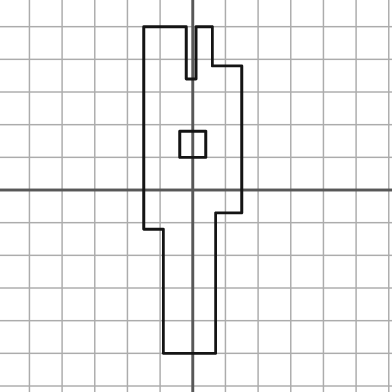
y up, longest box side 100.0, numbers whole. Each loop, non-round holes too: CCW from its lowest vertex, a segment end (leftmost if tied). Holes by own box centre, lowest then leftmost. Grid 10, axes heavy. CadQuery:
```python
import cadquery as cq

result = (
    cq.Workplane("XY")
    .moveTo(-9.0, -50.0)
    .lineTo(7.0, -50.0)
    .lineTo(7.0, -7.0)
    .lineTo(15.0, -7.0)
    .lineTo(15.0, 38.0)
    .lineTo(6.0, 38.0)
    .lineTo(6.0, 50.0)
    .lineTo(1.0, 50.0)
    .lineTo(1.0, 34.0)
    .lineTo(-2.0, 34.0)
    .lineTo(-2.0, 50.0)
    .lineTo(-15.0, 50.0)
    .lineTo(-15.0, -12.0)
    .lineTo(-9.0, -12.0)
    .close()
    .moveTo(-4.0, 10.0)
    .lineTo(4.0, 10.0)
    .lineTo(4.0, 18.0)
    .lineTo(-4.0, 18.0)
    .close()
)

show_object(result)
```